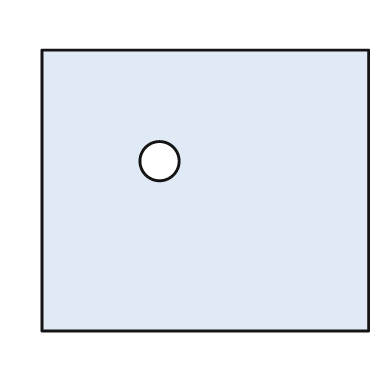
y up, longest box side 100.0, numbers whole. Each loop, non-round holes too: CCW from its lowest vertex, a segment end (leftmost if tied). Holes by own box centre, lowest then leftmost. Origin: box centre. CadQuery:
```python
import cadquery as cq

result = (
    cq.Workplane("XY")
    .moveTo(-50.0, -43.0)
    .lineTo(50.0, -43.0)
    .lineTo(50.0, 43.0)
    .lineTo(-50.0, 43.0)
    .close()
    .moveTo(-14.0, 9.0)
    .circle(6.0)
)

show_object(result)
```